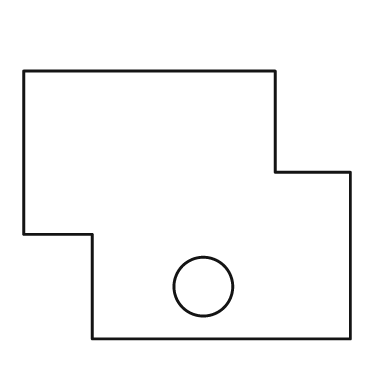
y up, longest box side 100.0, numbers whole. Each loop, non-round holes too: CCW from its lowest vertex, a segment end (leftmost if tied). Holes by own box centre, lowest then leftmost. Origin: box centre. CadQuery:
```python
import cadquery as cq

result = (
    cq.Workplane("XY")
    .moveTo(-29.0, -41.0)
    .lineTo(50.0, -41.0)
    .lineTo(50.0, 10.0)
    .lineTo(27.0, 10.0)
    .lineTo(27.0, 41.0)
    .lineTo(-50.0, 41.0)
    .lineTo(-50.0, -9.0)
    .lineTo(-29.0, -9.0)
    .close()
    .moveTo(5.0, -25.0)
    .circle(9.0)
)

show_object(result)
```